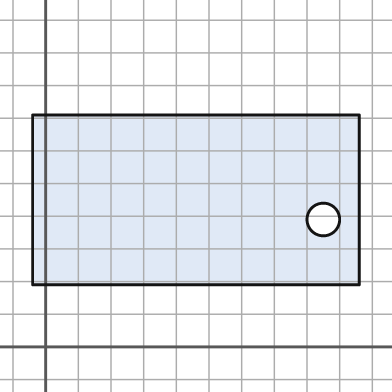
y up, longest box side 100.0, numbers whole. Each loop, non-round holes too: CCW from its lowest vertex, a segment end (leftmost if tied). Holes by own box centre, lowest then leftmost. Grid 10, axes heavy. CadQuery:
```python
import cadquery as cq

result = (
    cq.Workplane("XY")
    .moveTo(-4.0, 19.0)
    .lineTo(96.0, 19.0)
    .lineTo(96.0, 71.0)
    .lineTo(-4.0, 71.0)
    .close()
    .moveTo(85.0, 39.0)
    .circle(5.0)
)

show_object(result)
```